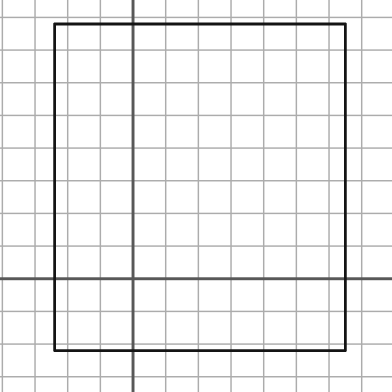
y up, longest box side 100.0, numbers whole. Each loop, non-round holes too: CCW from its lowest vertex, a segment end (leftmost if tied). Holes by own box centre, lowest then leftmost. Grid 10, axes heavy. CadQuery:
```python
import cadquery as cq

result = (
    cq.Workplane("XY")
    .moveTo(-24.0, -22.0)
    .lineTo(65.0, -22.0)
    .lineTo(65.0, 78.0)
    .lineTo(-24.0, 78.0)
    .close()
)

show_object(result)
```